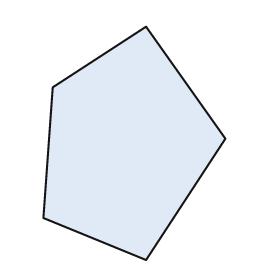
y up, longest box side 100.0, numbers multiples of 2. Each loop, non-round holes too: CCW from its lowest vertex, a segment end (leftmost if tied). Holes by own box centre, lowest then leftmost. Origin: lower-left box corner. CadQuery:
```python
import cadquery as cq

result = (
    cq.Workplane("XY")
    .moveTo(44.0, 0.0)
    .lineTo(78.0, 52.0)
    .lineTo(44.0, 100.0)
    .lineTo(4.0, 74.0)
    .lineTo(0.0, 18.0)
    .close()
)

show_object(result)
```